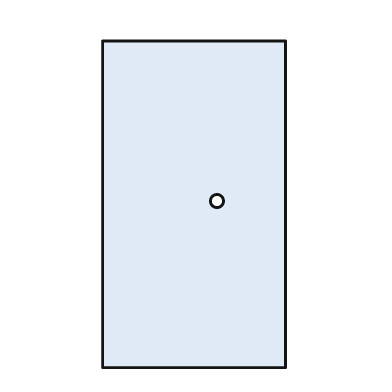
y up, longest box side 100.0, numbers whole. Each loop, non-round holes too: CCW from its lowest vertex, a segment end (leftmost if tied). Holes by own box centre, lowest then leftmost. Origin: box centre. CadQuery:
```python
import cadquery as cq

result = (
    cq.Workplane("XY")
    .moveTo(-28.0, -50.0)
    .lineTo(28.0, -50.0)
    .lineTo(28.0, 50.0)
    .lineTo(-28.0, 50.0)
    .close()
    .moveTo(7.0, 1.0)
    .circle(2.0)
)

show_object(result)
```